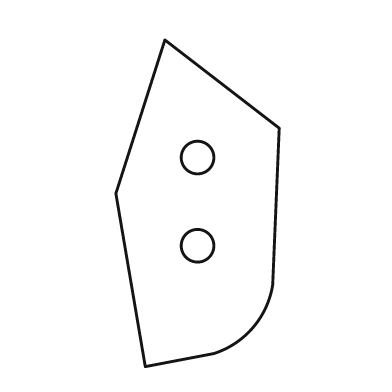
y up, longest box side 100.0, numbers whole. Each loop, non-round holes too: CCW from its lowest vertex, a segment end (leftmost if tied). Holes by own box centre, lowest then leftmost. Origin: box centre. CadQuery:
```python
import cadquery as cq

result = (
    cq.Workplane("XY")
    .moveTo(-16.0, -50.0)
    .lineTo(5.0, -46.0)
    .threePointArc((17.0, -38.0), (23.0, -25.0))
    .lineTo(25.0, 23.0)
    .lineTo(-10.0, 50.0)
    .lineTo(-25.0, 3.0)
    .close()
    .moveTo(0.0, -13.0)
    .circle(5.0)
    .moveTo(0.0, 14.0)
    .circle(5.0)
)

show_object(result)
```